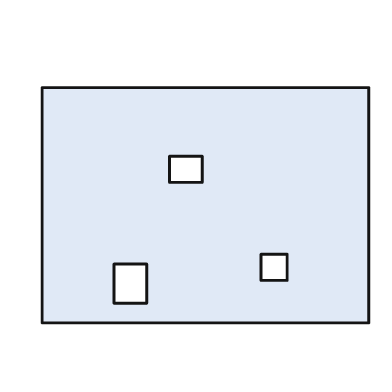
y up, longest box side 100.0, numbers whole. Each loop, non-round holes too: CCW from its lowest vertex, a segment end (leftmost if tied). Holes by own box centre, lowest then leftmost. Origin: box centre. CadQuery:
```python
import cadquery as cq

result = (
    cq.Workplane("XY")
    .moveTo(-50.0, -36.0)
    .lineTo(50.0, -36.0)
    .lineTo(50.0, 36.0)
    .lineTo(-50.0, 36.0)
    .close()
    .moveTo(-28.0, -30.0)
    .lineTo(-18.0, -30.0)
    .lineTo(-18.0, -18.0)
    .lineTo(-28.0, -18.0)
    .close()
    .moveTo(17.0, -23.0)
    .lineTo(25.0, -23.0)
    .lineTo(25.0, -15.0)
    .lineTo(17.0, -15.0)
    .close()
    .moveTo(-11.0, 7.0)
    .lineTo(-1.0, 7.0)
    .lineTo(-1.0, 15.0)
    .lineTo(-11.0, 15.0)
    .close()
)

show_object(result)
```